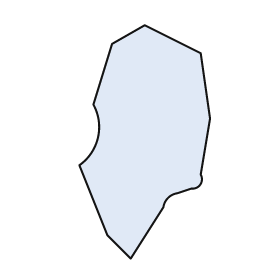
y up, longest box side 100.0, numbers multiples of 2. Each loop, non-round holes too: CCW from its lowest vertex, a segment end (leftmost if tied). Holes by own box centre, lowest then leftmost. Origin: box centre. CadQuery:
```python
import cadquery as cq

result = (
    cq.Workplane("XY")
    .moveTo(-6.0, -50.0)
    .lineTo(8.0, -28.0)
    .threePointArc((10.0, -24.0), (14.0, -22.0))
    .lineTo(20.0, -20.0)
    .threePointArc((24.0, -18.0), (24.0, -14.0))
    .lineTo(28.0, 10.0)
    .lineTo(24.0, 38.0)
    .lineTo(0.0, 50.0)
    .lineTo(-14.0, 42.0)
    .lineTo(-22.0, 16.0)
    .threePointArc((-20.0, 2.0), (-28.0, -10.0))
    .lineTo(-16.0, -40.0)
    .close()
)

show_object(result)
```